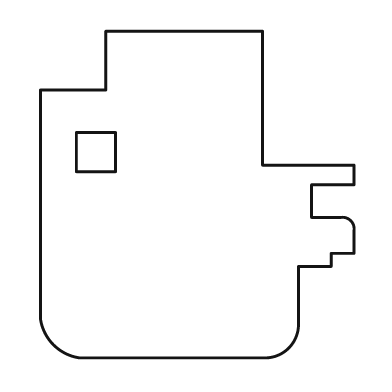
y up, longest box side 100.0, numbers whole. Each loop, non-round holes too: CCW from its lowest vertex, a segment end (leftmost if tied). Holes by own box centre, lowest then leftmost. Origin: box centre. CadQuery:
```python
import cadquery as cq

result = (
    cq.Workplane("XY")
    .moveTo(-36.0, -50.0)
    .lineTo(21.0, -50.0)
    .threePointArc((28.0, -47.0), (31.0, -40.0))
    .lineTo(31.0, -22.0)
    .lineTo(41.0, -22.0)
    .lineTo(41.0, -18.0)
    .lineTo(48.0, -18.0)
    .lineTo(48.0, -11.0)
    .threePointArc((47.0, -8.0), (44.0, -7.0))
    .lineTo(35.0, -7.0)
    .lineTo(35.0, 3.0)
    .lineTo(48.0, 3.0)
    .lineTo(48.0, 9.0)
    .lineTo(20.0, 9.0)
    .lineTo(20.0, 50.0)
    .lineTo(-28.0, 50.0)
    .lineTo(-28.0, 32.0)
    .lineTo(-48.0, 32.0)
    .lineTo(-48.0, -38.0)
    .threePointArc((-44.0, -46.0), (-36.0, -50.0))
    .close()
    .moveTo(-37.0, 7.0)
    .lineTo(-25.0, 7.0)
    .lineTo(-25.0, 19.0)
    .lineTo(-37.0, 19.0)
    .close()
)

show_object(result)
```